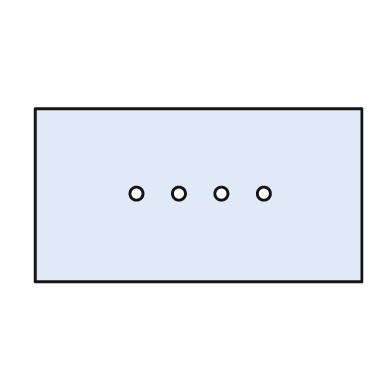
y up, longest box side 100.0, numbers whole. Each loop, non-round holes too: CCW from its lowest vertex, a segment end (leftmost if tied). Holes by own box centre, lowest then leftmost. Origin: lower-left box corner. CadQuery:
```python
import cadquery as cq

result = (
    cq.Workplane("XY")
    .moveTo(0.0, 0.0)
    .lineTo(100.0, 0.0)
    .lineTo(100.0, 53.0)
    .lineTo(0.0, 53.0)
    .close()
    .moveTo(31.0, 27.0)
    .circle(2.0)
    .moveTo(44.0, 27.0)
    .circle(2.0)
    .moveTo(57.0, 27.0)
    .circle(2.0)
    .moveTo(70.0, 27.0)
    .circle(2.0)
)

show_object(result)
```